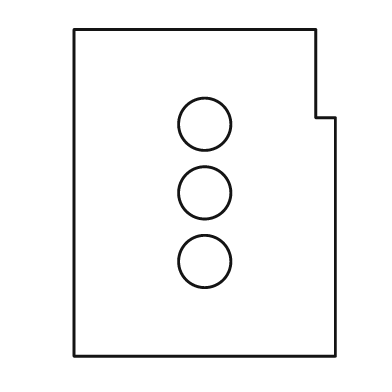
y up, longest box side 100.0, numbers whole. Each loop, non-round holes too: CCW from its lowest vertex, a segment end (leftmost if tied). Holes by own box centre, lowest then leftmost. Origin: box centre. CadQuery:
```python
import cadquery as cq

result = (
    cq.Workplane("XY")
    .moveTo(-40.0, -50.0)
    .lineTo(40.0, -50.0)
    .lineTo(40.0, 23.0)
    .lineTo(34.0, 23.0)
    .lineTo(34.0, 50.0)
    .lineTo(-40.0, 50.0)
    .close()
    .moveTo(0.0, -21.0)
    .circle(8.0)
    .moveTo(0.0, 0.0)
    .circle(8.0)
    .moveTo(0.0, 21.0)
    .circle(8.0)
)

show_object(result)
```